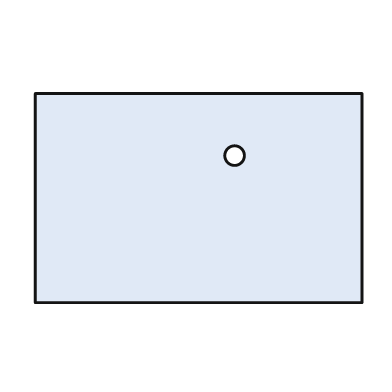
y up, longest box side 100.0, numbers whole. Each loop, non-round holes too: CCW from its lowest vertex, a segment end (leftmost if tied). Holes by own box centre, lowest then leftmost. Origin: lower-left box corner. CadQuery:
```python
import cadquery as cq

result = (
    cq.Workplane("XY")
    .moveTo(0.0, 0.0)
    .lineTo(100.0, 0.0)
    .lineTo(100.0, 64.0)
    .lineTo(0.0, 64.0)
    .close()
    .moveTo(61.0, 45.0)
    .circle(3.0)
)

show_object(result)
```